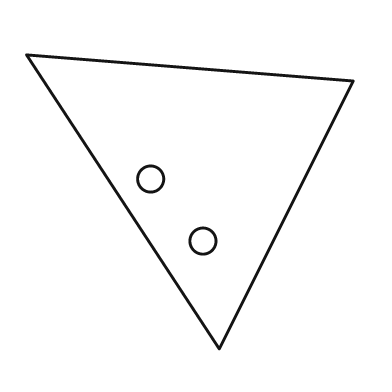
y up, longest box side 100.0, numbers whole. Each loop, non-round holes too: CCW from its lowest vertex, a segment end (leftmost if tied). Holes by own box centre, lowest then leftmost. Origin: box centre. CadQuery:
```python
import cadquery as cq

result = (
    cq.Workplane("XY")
    .moveTo(9.0, -45.0)
    .lineTo(50.0, 37.0)
    .lineTo(-50.0, 45.0)
    .close()
    .moveTo(4.0, -12.0)
    .circle(4.0)
    .moveTo(-12.0, 7.0)
    .circle(4.0)
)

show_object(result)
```